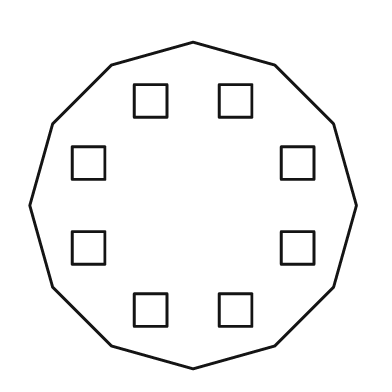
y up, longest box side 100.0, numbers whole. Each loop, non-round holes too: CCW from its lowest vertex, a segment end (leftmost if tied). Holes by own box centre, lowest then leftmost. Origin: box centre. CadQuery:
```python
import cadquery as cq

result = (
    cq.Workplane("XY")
    .moveTo(0.0, -50.0)
    .lineTo(25.0, -43.0)
    .lineTo(43.0, -25.0)
    .lineTo(50.0, 0.0)
    .lineTo(43.0, 25.0)
    .lineTo(25.0, 43.0)
    .lineTo(0.0, 50.0)
    .lineTo(-25.0, 43.0)
    .lineTo(-43.0, 25.0)
    .lineTo(-50.0, 0.0)
    .lineTo(-43.0, -25.0)
    .lineTo(-25.0, -43.0)
    .close()
    .moveTo(-18.0, -37.0)
    .lineTo(-8.0, -37.0)
    .lineTo(-8.0, -27.0)
    .lineTo(-18.0, -27.0)
    .close()
    .moveTo(8.0, -37.0)
    .lineTo(18.0, -37.0)
    .lineTo(18.0, -27.0)
    .lineTo(8.0, -27.0)
    .close()
    .moveTo(-37.0, -18.0)
    .lineTo(-27.0, -18.0)
    .lineTo(-27.0, -8.0)
    .lineTo(-37.0, -8.0)
    .close()
    .moveTo(27.0, -18.0)
    .lineTo(37.0, -18.0)
    .lineTo(37.0, -8.0)
    .lineTo(27.0, -8.0)
    .close()
    .moveTo(-37.0, 8.0)
    .lineTo(-27.0, 8.0)
    .lineTo(-27.0, 18.0)
    .lineTo(-37.0, 18.0)
    .close()
    .moveTo(27.0, 8.0)
    .lineTo(37.0, 8.0)
    .lineTo(37.0, 18.0)
    .lineTo(27.0, 18.0)
    .close()
    .moveTo(-18.0, 27.0)
    .lineTo(-8.0, 27.0)
    .lineTo(-8.0, 37.0)
    .lineTo(-18.0, 37.0)
    .close()
    .moveTo(8.0, 27.0)
    .lineTo(18.0, 27.0)
    .lineTo(18.0, 37.0)
    .lineTo(8.0, 37.0)
    .close()
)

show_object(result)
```